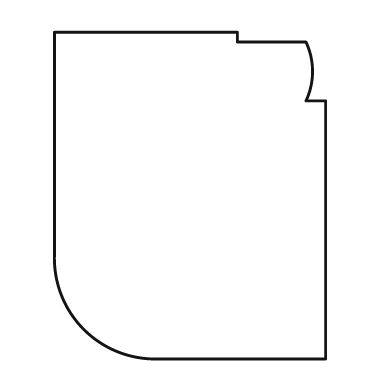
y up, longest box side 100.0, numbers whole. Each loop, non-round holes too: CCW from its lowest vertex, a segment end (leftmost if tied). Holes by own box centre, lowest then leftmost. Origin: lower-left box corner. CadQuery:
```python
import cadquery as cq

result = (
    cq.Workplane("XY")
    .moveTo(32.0, 0.0)
    .lineTo(83.0, 0.0)
    .lineTo(83.0, 79.0)
    .lineTo(77.0, 79.0)
    .threePointArc((79.0, 88.0), (77.0, 97.0))
    .lineTo(56.0, 97.0)
    .lineTo(56.0, 100.0)
    .lineTo(0.0, 100.0)
    .lineTo(0.0, 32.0)
    .threePointArc((9.0, 9.0), (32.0, 0.0))
    .close()
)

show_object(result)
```